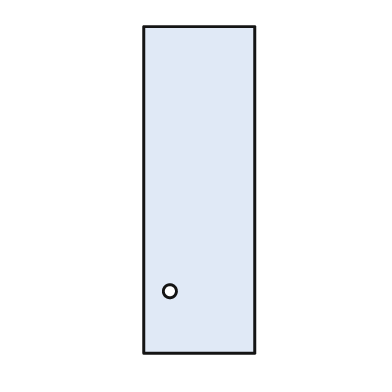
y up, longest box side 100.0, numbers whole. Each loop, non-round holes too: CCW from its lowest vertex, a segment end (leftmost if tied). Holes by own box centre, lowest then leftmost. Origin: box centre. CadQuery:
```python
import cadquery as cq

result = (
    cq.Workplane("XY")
    .moveTo(-17.0, -50.0)
    .lineTo(17.0, -50.0)
    .lineTo(17.0, 50.0)
    .lineTo(-17.0, 50.0)
    .close()
    .moveTo(-9.0, -31.0)
    .circle(2.0)
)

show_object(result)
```